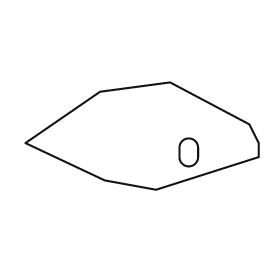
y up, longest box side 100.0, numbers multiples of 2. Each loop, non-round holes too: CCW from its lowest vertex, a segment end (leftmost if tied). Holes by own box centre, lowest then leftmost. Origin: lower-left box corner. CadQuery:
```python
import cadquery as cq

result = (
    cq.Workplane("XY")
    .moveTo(56.0, 0.0)
    .lineTo(100.0, 14.0)
    .lineTo(100.0, 20.0)
    .lineTo(96.0, 28.0)
    .lineTo(62.0, 46.0)
    .lineTo(32.0, 42.0)
    .lineTo(0.0, 20.0)
    .lineTo(34.0, 4.0)
    .close()
    .moveTo(66.0, 14.0)
    .threePointArc((70.0, 10.0), (74.0, 14.0))
    .lineTo(74.0, 18.0)
    .threePointArc((70.0, 22.0), (66.0, 18.0))
    .close()
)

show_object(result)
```